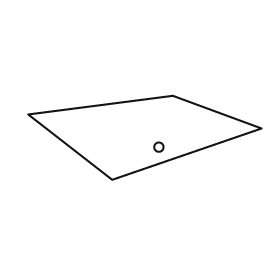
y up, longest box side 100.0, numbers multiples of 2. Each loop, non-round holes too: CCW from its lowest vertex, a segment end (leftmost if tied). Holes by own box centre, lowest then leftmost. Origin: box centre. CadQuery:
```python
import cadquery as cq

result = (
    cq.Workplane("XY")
    .moveTo(-14.0, -18.0)
    .lineTo(50.0, 4.0)
    .lineTo(12.0, 18.0)
    .lineTo(-50.0, 10.0)
    .close()
    .moveTo(6.0, -4.0)
    .circle(2.0)
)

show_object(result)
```